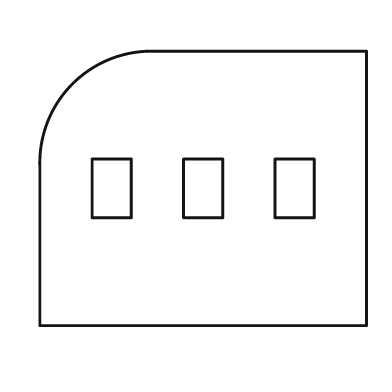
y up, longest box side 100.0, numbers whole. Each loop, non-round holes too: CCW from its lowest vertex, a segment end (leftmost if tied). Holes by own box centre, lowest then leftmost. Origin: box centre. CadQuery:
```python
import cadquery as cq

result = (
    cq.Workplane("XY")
    .moveTo(-50.0, -42.0)
    .lineTo(50.0, -42.0)
    .lineTo(50.0, 42.0)
    .lineTo(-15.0, 42.0)
    .threePointArc((-40.0, 32.0), (-50.0, 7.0))
    .close()
    .moveTo(-34.0, -9.0)
    .lineTo(-22.0, -9.0)
    .lineTo(-22.0, 9.0)
    .lineTo(-34.0, 9.0)
    .close()
    .moveTo(-6.0, -9.0)
    .lineTo(6.0, -9.0)
    .lineTo(6.0, 9.0)
    .lineTo(-6.0, 9.0)
    .close()
    .moveTo(22.0, -9.0)
    .lineTo(34.0, -9.0)
    .lineTo(34.0, 9.0)
    .lineTo(22.0, 9.0)
    .close()
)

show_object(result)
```